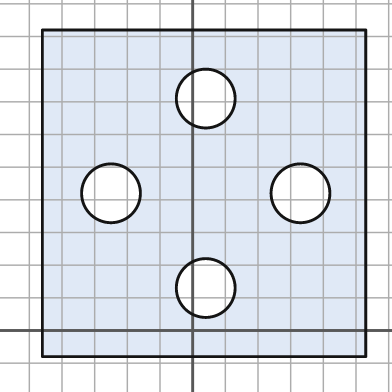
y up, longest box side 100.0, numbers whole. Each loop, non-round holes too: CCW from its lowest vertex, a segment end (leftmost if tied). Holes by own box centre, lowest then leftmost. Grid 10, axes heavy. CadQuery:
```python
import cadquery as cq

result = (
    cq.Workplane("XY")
    .moveTo(-46.0, -8.0)
    .lineTo(53.0, -8.0)
    .lineTo(53.0, 92.0)
    .lineTo(-46.0, 92.0)
    .close()
    .moveTo(4.0, 13.0)
    .circle(9.0)
    .moveTo(-25.0, 42.0)
    .circle(9.0)
    .moveTo(33.0, 42.0)
    .circle(9.0)
    .moveTo(4.0, 71.0)
    .circle(9.0)
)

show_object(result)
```